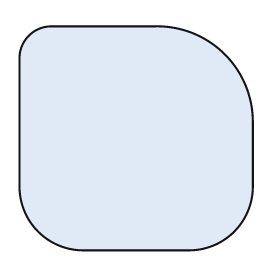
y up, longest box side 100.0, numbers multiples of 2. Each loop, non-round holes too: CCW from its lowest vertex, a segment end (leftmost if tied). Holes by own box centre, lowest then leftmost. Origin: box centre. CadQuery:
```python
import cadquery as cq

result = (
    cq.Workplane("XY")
    .moveTo(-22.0, -48.0)
    .lineTo(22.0, -48.0)
    .threePointArc((42.0, -40.0), (50.0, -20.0))
    .lineTo(50.0, 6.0)
    .threePointArc((38.0, 36.0), (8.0, 48.0))
    .lineTo(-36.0, 48.0)
    .threePointArc((-46.0, 44.0), (-50.0, 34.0))
    .lineTo(-50.0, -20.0)
    .threePointArc((-42.0, -40.0), (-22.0, -48.0))
    .close()
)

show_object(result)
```